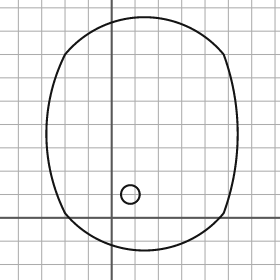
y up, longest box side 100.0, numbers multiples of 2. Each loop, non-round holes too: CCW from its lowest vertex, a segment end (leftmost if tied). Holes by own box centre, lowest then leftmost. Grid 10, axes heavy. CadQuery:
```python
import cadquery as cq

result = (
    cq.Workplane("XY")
    .moveTo(-20.0, 2.0)
    .threePointArc((14.0, -14.0), (48.0, 2.0))
    .threePointArc((54.0, 36.0), (48.0, 70.0))
    .threePointArc((14.0, 86.0), (-20.0, 70.0))
    .threePointArc((-28.0, 36.0), (-20.0, 2.0))
    .close()
    .moveTo(8.0, 10.0)
    .circle(4.0)
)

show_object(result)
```